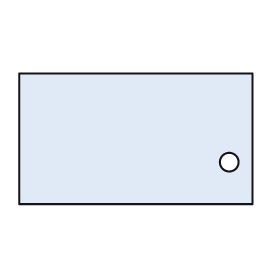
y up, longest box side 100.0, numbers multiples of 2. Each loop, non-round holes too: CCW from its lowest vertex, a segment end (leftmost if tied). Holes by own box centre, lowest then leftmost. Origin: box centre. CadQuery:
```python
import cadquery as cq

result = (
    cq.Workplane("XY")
    .moveTo(-50.0, -28.0)
    .lineTo(50.0, -28.0)
    .lineTo(50.0, 28.0)
    .lineTo(-50.0, 28.0)
    .close()
    .moveTo(40.0, -10.0)
    .circle(4.0)
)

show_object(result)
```